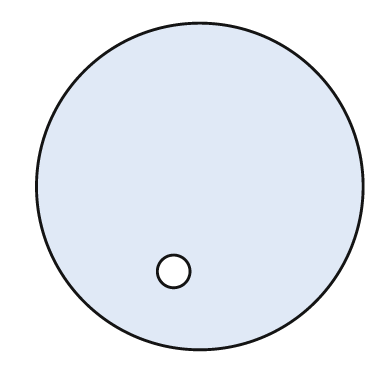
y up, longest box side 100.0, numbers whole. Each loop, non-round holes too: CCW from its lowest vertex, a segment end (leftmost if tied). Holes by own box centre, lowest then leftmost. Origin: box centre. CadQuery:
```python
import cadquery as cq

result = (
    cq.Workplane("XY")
    .moveTo(0.0, 0.0)
    .circle(50.0)
    .moveTo(-8.0, -26.0)
    .circle(5.0)
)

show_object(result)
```